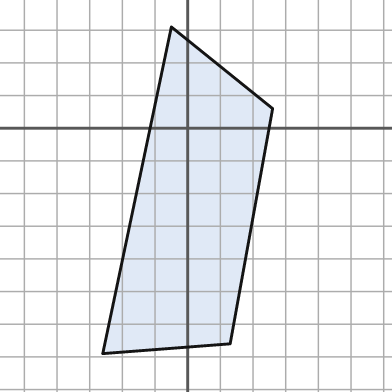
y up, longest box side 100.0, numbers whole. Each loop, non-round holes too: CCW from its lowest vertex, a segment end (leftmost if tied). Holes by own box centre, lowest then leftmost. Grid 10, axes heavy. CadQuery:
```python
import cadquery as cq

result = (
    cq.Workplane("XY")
    .moveTo(-26.0, -69.0)
    .lineTo(13.0, -66.0)
    .lineTo(26.0, 6.0)
    .lineTo(-5.0, 31.0)
    .close()
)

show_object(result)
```